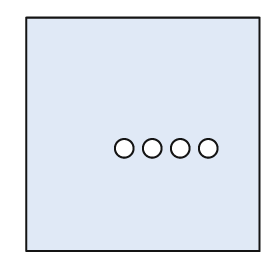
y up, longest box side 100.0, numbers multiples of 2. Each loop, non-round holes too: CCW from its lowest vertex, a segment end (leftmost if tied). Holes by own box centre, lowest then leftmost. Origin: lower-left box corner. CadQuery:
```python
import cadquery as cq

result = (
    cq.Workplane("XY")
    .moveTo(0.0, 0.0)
    .lineTo(100.0, 0.0)
    .lineTo(100.0, 100.0)
    .lineTo(0.0, 100.0)
    .close()
    .moveTo(42.0, 44.0)
    .circle(4.0)
    .moveTo(54.0, 44.0)
    .circle(4.0)
    .moveTo(66.0, 44.0)
    .circle(4.0)
    .moveTo(78.0, 44.0)
    .circle(4.0)
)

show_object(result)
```